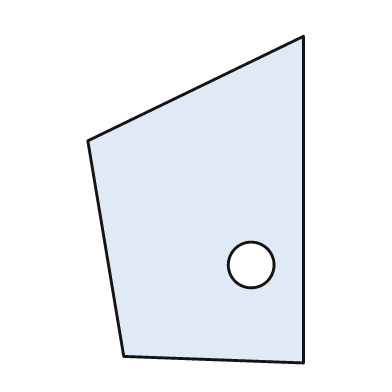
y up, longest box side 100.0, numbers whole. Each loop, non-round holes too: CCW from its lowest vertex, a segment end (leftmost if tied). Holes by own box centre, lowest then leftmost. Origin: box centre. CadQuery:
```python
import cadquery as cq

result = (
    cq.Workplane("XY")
    .moveTo(33.0, -50.0)
    .lineTo(33.0, 50.0)
    .lineTo(-33.0, 18.0)
    .lineTo(-22.0, -48.0)
    .close()
    .moveTo(17.0, -20.0)
    .circle(7.0)
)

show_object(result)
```